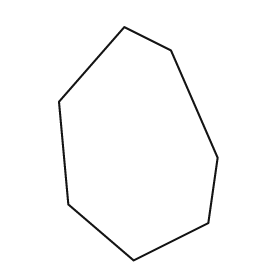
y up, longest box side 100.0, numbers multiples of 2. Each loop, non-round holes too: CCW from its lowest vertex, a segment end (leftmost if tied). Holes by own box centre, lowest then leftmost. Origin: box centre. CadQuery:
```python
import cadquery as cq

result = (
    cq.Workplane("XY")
    .moveTo(-2.0, -50.0)
    .lineTo(30.0, -34.0)
    .lineTo(34.0, -6.0)
    .lineTo(14.0, 40.0)
    .lineTo(-6.0, 50.0)
    .lineTo(-34.0, 18.0)
    .lineTo(-30.0, -26.0)
    .close()
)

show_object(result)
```